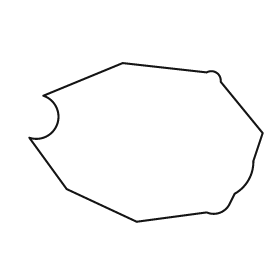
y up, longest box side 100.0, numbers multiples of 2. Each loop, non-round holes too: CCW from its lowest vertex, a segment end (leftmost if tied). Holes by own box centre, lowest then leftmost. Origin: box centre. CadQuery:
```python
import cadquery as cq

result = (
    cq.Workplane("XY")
    .moveTo(-4.0, -34.0)
    .lineTo(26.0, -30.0)
    .threePointArc((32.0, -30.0), (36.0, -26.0))
    .lineTo(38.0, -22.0)
    .threePointArc((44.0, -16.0), (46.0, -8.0))
    .lineTo(50.0, 4.0)
    .lineTo(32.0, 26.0)
    .threePointArc((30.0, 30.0), (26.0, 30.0))
    .lineTo(-10.0, 34.0)
    .lineTo(-44.0, 20.0)
    .threePointArc((-38.0, 8.0), (-50.0, 2.0))
    .lineTo(-34.0, -20.0)
    .close()
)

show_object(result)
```